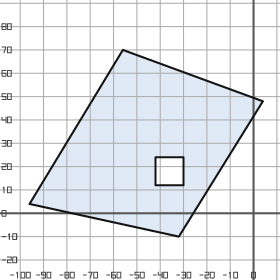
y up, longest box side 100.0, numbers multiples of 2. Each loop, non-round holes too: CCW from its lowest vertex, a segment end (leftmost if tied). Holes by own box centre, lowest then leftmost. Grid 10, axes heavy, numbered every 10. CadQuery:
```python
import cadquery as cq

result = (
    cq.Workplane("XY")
    .moveTo(-32.0, -10.0)
    .lineTo(4.0, 48.0)
    .lineTo(-56.0, 70.0)
    .lineTo(-96.0, 4.0)
    .close()
    .moveTo(-42.0, 12.0)
    .lineTo(-30.0, 12.0)
    .lineTo(-30.0, 24.0)
    .lineTo(-42.0, 24.0)
    .close()
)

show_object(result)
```